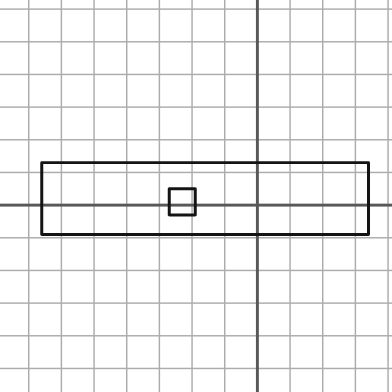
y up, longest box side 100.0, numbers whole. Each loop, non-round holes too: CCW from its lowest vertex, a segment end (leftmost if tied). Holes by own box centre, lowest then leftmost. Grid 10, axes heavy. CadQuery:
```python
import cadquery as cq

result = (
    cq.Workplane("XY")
    .moveTo(-66.0, -9.0)
    .lineTo(34.0, -9.0)
    .lineTo(34.0, 13.0)
    .lineTo(-66.0, 13.0)
    .close()
    .moveTo(-27.0, -3.0)
    .lineTo(-19.0, -3.0)
    .lineTo(-19.0, 5.0)
    .lineTo(-27.0, 5.0)
    .close()
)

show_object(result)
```